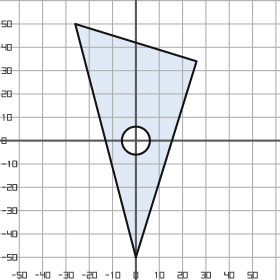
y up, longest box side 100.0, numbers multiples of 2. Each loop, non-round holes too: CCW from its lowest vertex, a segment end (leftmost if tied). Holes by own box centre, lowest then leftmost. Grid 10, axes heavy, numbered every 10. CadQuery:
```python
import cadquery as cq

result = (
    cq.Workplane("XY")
    .moveTo(0.0, -50.0)
    .lineTo(26.0, 34.0)
    .lineTo(-26.0, 50.0)
    .close()
    .moveTo(0.0, 0.0)
    .circle(6.0)
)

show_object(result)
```